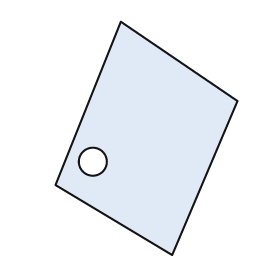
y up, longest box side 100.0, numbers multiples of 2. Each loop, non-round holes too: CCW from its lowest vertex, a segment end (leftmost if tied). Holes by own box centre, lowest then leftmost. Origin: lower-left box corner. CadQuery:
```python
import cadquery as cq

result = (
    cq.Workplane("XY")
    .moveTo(50.0, 0.0)
    .lineTo(78.0, 66.0)
    .lineTo(28.0, 100.0)
    .lineTo(0.0, 30.0)
    .close()
    .moveTo(16.0, 40.0)
    .circle(6.0)
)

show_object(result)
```